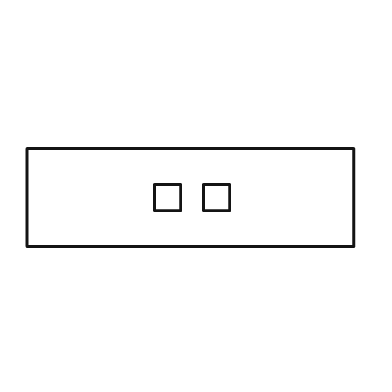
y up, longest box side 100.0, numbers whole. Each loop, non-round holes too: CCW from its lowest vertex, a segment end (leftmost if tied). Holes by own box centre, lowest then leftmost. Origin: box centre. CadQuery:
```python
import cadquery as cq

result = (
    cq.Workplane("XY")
    .moveTo(-50.0, -15.0)
    .lineTo(50.0, -15.0)
    .lineTo(50.0, 15.0)
    .lineTo(-50.0, 15.0)
    .close()
    .moveTo(-11.0, -4.0)
    .lineTo(-3.0, -4.0)
    .lineTo(-3.0, 4.0)
    .lineTo(-11.0, 4.0)
    .close()
    .moveTo(4.0, -4.0)
    .lineTo(12.0, -4.0)
    .lineTo(12.0, 4.0)
    .lineTo(4.0, 4.0)
    .close()
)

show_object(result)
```